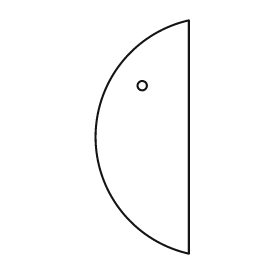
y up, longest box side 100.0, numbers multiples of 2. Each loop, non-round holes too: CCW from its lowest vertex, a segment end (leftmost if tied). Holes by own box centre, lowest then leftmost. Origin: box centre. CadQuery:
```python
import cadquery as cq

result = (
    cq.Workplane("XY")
    .moveTo(20.0, -50.0)
    .lineTo(20.0, 50.0)
    .threePointArc((-20.0, 0.0), (20.0, -50.0))
    .close()
    .moveTo(0.0, 22.0)
    .circle(2.0)
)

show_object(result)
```